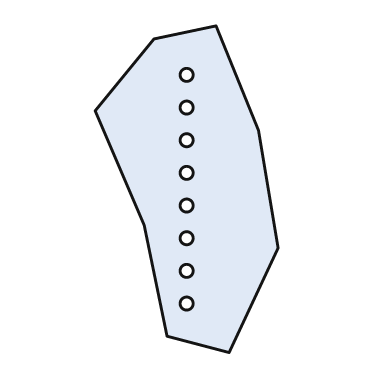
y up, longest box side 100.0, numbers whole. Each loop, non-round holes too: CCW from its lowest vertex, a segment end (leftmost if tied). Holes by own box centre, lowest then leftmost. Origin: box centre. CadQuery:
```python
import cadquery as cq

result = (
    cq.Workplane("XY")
    .moveTo(13.0, -50.0)
    .lineTo(28.0, -18.0)
    .lineTo(22.0, 18.0)
    .lineTo(9.0, 50.0)
    .lineTo(-10.0, 46.0)
    .lineTo(-28.0, 24.0)
    .lineTo(-13.0, -11.0)
    .lineTo(-6.0, -45.0)
    .close()
    .moveTo(0.0, -35.0)
    .circle(2.0)
    .moveTo(0.0, -25.0)
    .circle(2.0)
    .moveTo(0.0, -15.0)
    .circle(2.0)
    .moveTo(0.0, -5.0)
    .circle(2.0)
    .moveTo(0.0, 5.0)
    .circle(2.0)
    .moveTo(0.0, 15.0)
    .circle(2.0)
    .moveTo(0.0, 25.0)
    .circle(2.0)
    .moveTo(0.0, 35.0)
    .circle(2.0)
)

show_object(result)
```